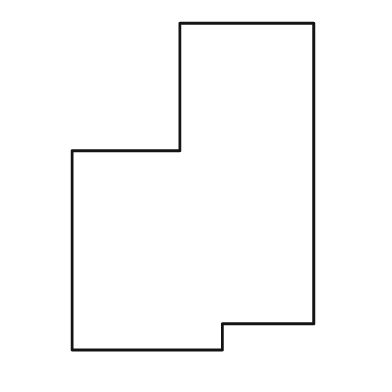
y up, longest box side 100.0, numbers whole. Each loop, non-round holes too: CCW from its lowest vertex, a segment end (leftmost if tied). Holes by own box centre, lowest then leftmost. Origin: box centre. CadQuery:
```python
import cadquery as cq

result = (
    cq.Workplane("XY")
    .moveTo(-37.0, -50.0)
    .lineTo(9.0, -50.0)
    .lineTo(9.0, -42.0)
    .lineTo(37.0, -42.0)
    .lineTo(37.0, 50.0)
    .lineTo(-4.0, 50.0)
    .lineTo(-4.0, 11.0)
    .lineTo(-37.0, 11.0)
    .close()
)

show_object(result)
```